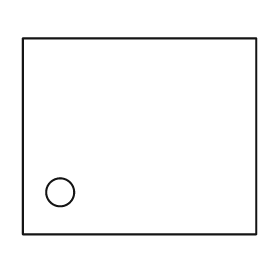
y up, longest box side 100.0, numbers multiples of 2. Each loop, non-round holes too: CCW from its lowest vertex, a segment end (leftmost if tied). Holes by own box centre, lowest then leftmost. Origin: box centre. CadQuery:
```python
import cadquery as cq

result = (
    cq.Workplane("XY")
    .moveTo(-50.0, -42.0)
    .lineTo(50.0, -42.0)
    .lineTo(50.0, 42.0)
    .lineTo(-50.0, 42.0)
    .close()
    .moveTo(-34.0, -24.0)
    .circle(6.0)
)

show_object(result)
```